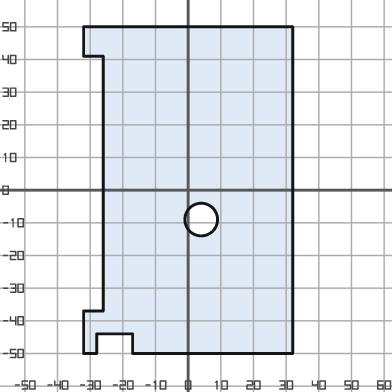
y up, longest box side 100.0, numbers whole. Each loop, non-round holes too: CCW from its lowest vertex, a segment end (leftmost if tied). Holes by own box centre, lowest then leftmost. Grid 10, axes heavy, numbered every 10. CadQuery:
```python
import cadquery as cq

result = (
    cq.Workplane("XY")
    .moveTo(-32.0, -50.0)
    .lineTo(-28.0, -50.0)
    .lineTo(-28.0, -44.0)
    .lineTo(-17.0, -44.0)
    .lineTo(-17.0, -50.0)
    .lineTo(32.0, -50.0)
    .lineTo(32.0, 50.0)
    .lineTo(-32.0, 50.0)
    .lineTo(-32.0, 41.0)
    .lineTo(-26.0, 41.0)
    .lineTo(-26.0, -37.0)
    .lineTo(-32.0, -37.0)
    .close()
    .moveTo(4.0, -9.0)
    .circle(5.0)
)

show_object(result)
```